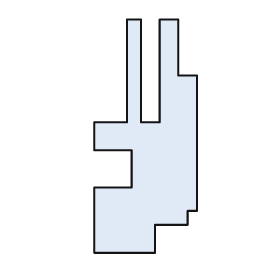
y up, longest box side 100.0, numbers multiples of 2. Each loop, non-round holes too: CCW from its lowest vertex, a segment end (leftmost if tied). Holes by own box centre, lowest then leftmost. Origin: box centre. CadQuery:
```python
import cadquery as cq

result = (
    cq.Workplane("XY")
    .moveTo(-22.0, -50.0)
    .lineTo(4.0, -50.0)
    .lineTo(4.0, -38.0)
    .lineTo(18.0, -38.0)
    .lineTo(18.0, -32.0)
    .lineTo(22.0, -32.0)
    .lineTo(22.0, 26.0)
    .lineTo(14.0, 26.0)
    .lineTo(14.0, 50.0)
    .lineTo(6.0, 50.0)
    .lineTo(6.0, 6.0)
    .lineTo(-2.0, 6.0)
    .lineTo(-2.0, 50.0)
    .lineTo(-8.0, 50.0)
    .lineTo(-8.0, 6.0)
    .lineTo(-22.0, 6.0)
    .lineTo(-22.0, -6.0)
    .lineTo(-6.0, -6.0)
    .lineTo(-6.0, -22.0)
    .lineTo(-22.0, -22.0)
    .close()
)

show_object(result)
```